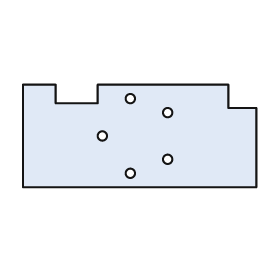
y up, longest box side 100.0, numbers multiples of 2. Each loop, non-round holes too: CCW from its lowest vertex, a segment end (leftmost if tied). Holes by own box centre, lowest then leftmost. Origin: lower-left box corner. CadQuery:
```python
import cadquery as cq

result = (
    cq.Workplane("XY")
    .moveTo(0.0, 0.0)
    .lineTo(100.0, 0.0)
    .lineTo(100.0, 34.0)
    .lineTo(88.0, 34.0)
    .lineTo(88.0, 44.0)
    .lineTo(32.0, 44.0)
    .lineTo(32.0, 36.0)
    .lineTo(14.0, 36.0)
    .lineTo(14.0, 44.0)
    .lineTo(0.0, 44.0)
    .close()
    .moveTo(46.0, 6.0)
    .circle(2.0)
    .moveTo(62.0, 12.0)
    .circle(2.0)
    .moveTo(34.0, 22.0)
    .circle(2.0)
    .moveTo(62.0, 32.0)
    .circle(2.0)
    .moveTo(46.0, 38.0)
    .circle(2.0)
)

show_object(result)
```